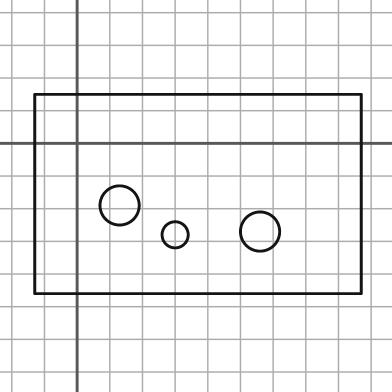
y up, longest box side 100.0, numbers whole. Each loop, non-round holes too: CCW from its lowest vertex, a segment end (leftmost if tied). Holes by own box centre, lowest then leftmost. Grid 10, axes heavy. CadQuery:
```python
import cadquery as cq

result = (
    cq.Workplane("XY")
    .moveTo(-13.0, -46.0)
    .lineTo(87.0, -46.0)
    .lineTo(87.0, 15.0)
    .lineTo(-13.0, 15.0)
    .close()
    .moveTo(30.0, -28.0)
    .circle(4.0)
    .moveTo(56.0, -27.0)
    .circle(6.0)
    .moveTo(13.0, -19.0)
    .circle(6.0)
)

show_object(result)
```